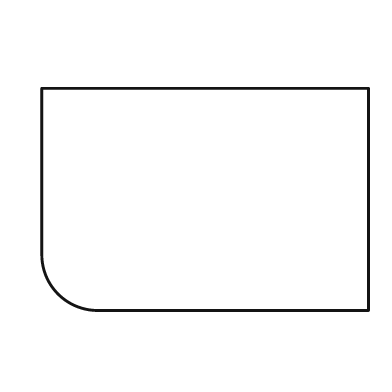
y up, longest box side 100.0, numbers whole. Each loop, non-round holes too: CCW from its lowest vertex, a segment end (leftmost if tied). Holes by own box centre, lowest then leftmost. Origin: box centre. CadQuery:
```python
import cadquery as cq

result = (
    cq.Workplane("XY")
    .moveTo(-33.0, -34.0)
    .lineTo(50.0, -34.0)
    .lineTo(50.0, 34.0)
    .lineTo(-50.0, 34.0)
    .lineTo(-50.0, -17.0)
    .threePointArc((-45.0, -29.0), (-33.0, -34.0))
    .close()
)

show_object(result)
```